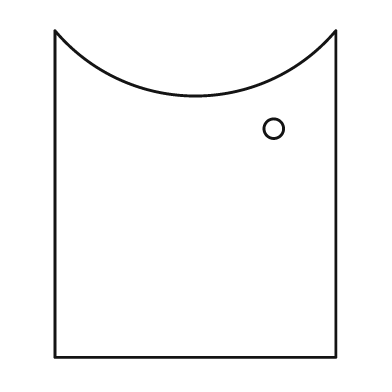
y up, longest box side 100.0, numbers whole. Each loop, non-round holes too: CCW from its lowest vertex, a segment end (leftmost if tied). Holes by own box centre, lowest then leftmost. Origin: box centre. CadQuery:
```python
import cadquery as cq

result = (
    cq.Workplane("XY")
    .moveTo(-43.0, -50.0)
    .lineTo(43.0, -50.0)
    .lineTo(43.0, 50.0)
    .threePointArc((0.0, 30.0), (-43.0, 50.0))
    .close()
    .moveTo(24.0, 20.0)
    .circle(3.0)
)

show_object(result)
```